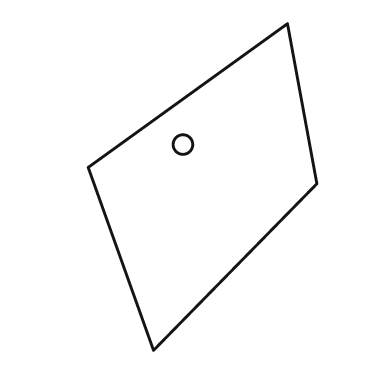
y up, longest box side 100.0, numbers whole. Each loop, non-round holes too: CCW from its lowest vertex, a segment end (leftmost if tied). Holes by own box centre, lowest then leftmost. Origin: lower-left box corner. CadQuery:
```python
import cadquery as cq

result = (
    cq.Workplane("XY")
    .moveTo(20.0, 0.0)
    .lineTo(70.0, 51.0)
    .lineTo(61.0, 100.0)
    .lineTo(0.0, 56.0)
    .close()
    .moveTo(29.0, 63.0)
    .circle(3.0)
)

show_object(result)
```